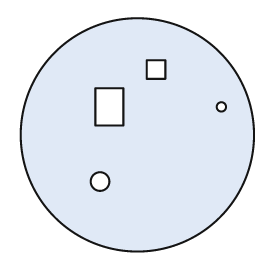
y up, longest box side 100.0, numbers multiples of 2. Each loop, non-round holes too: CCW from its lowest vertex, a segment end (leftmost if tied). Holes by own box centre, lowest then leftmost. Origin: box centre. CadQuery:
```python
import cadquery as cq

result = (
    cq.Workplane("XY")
    .moveTo(0.0, 0.0)
    .circle(50.0)
    .moveTo(-16.0, -20.0)
    .circle(4.0)
    .moveTo(-18.0, 4.0)
    .lineTo(-6.0, 4.0)
    .lineTo(-6.0, 20.0)
    .lineTo(-18.0, 20.0)
    .close()
    .moveTo(36.0, 12.0)
    .circle(2.0)
    .moveTo(4.0, 24.0)
    .lineTo(12.0, 24.0)
    .lineTo(12.0, 32.0)
    .lineTo(4.0, 32.0)
    .close()
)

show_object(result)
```